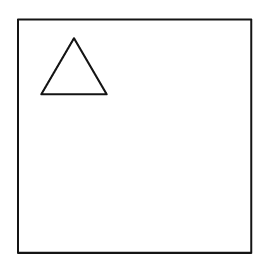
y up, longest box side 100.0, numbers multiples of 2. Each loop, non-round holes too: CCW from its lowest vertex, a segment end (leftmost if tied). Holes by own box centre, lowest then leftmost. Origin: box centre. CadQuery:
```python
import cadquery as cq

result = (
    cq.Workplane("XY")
    .moveTo(-50.0, -50.0)
    .lineTo(50.0, -50.0)
    .lineTo(50.0, 50.0)
    .lineTo(-50.0, 50.0)
    .close()
    .moveTo(-40.0, 18.0)
    .lineTo(-12.0, 18.0)
    .lineTo(-26.0, 42.0)
    .close()
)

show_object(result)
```